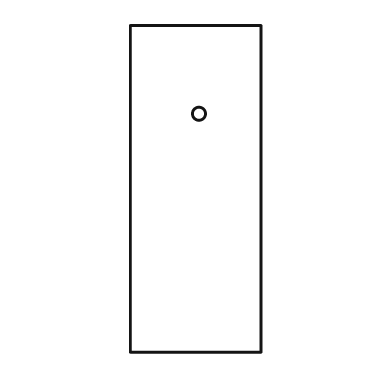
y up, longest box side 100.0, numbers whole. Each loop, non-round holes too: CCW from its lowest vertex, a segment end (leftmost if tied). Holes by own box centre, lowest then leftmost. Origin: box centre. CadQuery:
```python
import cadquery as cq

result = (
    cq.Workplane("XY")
    .moveTo(-20.0, -50.0)
    .lineTo(20.0, -50.0)
    .lineTo(20.0, 50.0)
    .lineTo(-20.0, 50.0)
    .close()
    .moveTo(1.0, 23.0)
    .circle(2.0)
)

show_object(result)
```